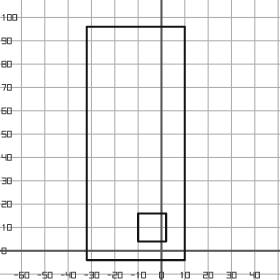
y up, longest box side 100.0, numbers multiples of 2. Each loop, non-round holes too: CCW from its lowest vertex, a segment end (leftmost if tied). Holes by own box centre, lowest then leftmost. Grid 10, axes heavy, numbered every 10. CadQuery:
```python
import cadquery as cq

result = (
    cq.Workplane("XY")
    .moveTo(-32.0, -4.0)
    .lineTo(10.0, -4.0)
    .lineTo(10.0, 96.0)
    .lineTo(-32.0, 96.0)
    .close()
    .moveTo(-10.0, 4.0)
    .lineTo(2.0, 4.0)
    .lineTo(2.0, 16.0)
    .lineTo(-10.0, 16.0)
    .close()
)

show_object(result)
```